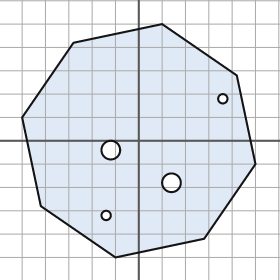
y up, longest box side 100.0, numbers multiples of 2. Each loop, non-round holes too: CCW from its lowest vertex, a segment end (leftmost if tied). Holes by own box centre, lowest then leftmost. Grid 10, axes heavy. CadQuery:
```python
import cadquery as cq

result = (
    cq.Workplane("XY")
    .moveTo(-10.0, -50.0)
    .lineTo(28.0, -42.0)
    .lineTo(50.0, -10.0)
    .lineTo(42.0, 28.0)
    .lineTo(10.0, 50.0)
    .lineTo(-28.0, 42.0)
    .lineTo(-50.0, 10.0)
    .lineTo(-42.0, -28.0)
    .close()
    .moveTo(-14.0, -32.0)
    .circle(2.0)
    .moveTo(14.0, -18.0)
    .circle(4.0)
    .moveTo(-12.0, -4.0)
    .circle(4.0)
    .moveTo(36.0, 18.0)
    .circle(2.0)
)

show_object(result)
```